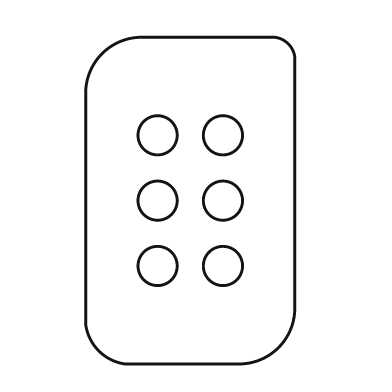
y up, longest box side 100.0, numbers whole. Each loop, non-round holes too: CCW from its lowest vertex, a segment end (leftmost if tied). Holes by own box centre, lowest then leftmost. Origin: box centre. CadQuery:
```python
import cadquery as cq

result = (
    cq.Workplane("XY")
    .moveTo(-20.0, -50.0)
    .lineTo(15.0, -50.0)
    .threePointArc((27.0, -45.0), (32.0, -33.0))
    .lineTo(32.0, 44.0)
    .threePointArc((30.0, 48.0), (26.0, 50.0))
    .lineTo(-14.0, 50.0)
    .threePointArc((-27.0, 45.0), (-32.0, 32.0))
    .lineTo(-32.0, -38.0)
    .threePointArc((-28.0, -46.0), (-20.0, -50.0))
    .close()
    .moveTo(-10.0, -20.0)
    .circle(6.0)
    .moveTo(10.0, -20.0)
    .circle(6.0)
    .moveTo(-10.0, 0.0)
    .circle(6.0)
    .moveTo(10.0, 0.0)
    .circle(6.0)
    .moveTo(-10.0, 20.0)
    .circle(6.0)
    .moveTo(10.0, 20.0)
    .circle(6.0)
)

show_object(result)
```